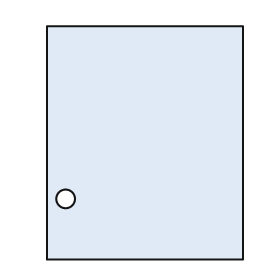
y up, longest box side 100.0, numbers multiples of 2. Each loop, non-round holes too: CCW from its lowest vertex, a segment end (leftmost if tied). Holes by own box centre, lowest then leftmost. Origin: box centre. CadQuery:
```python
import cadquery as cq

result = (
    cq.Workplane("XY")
    .moveTo(-42.0, -50.0)
    .lineTo(42.0, -50.0)
    .lineTo(42.0, 50.0)
    .lineTo(-42.0, 50.0)
    .close()
    .moveTo(-34.0, -24.0)
    .circle(4.0)
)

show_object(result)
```